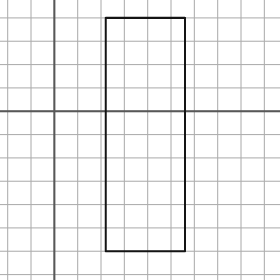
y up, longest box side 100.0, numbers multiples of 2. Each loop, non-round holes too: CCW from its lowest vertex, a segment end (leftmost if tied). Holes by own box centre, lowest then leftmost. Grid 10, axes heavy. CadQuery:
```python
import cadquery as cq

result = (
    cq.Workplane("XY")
    .moveTo(22.0, -60.0)
    .lineTo(56.0, -60.0)
    .lineTo(56.0, 40.0)
    .lineTo(22.0, 40.0)
    .close()
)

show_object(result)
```